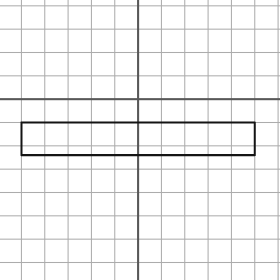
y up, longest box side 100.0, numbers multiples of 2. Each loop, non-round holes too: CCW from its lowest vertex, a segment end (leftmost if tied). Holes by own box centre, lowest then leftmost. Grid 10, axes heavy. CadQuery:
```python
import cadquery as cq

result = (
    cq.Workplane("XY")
    .moveTo(-50.0, -24.0)
    .lineTo(50.0, -24.0)
    .lineTo(50.0, -10.0)
    .lineTo(-50.0, -10.0)
    .close()
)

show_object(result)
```